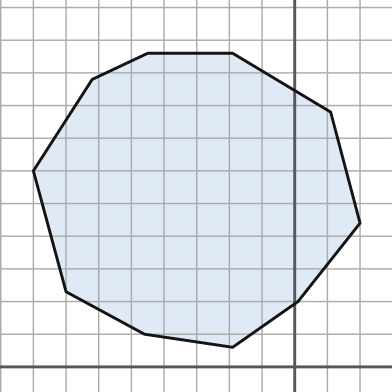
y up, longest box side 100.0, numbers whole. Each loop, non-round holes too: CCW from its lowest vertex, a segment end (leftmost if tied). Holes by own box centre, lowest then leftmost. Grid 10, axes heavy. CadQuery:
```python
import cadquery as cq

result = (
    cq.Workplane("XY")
    .moveTo(-19.0, 6.0)
    .lineTo(1.0, 20.0)
    .lineTo(20.0, 44.0)
    .lineTo(11.0, 78.0)
    .lineTo(-19.0, 96.0)
    .lineTo(-45.0, 96.0)
    .lineTo(-62.0, 88.0)
    .lineTo(-80.0, 60.0)
    .lineTo(-70.0, 23.0)
    .lineTo(-46.0, 10.0)
    .close()
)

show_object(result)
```